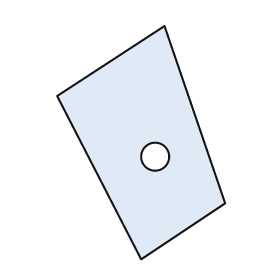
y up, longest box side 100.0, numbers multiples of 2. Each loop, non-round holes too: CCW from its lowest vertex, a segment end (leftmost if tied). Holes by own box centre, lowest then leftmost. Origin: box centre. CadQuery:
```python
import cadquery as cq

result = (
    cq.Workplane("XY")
    .moveTo(0.0, -50.0)
    .lineTo(36.0, -26.0)
    .lineTo(10.0, 50.0)
    .lineTo(-36.0, 20.0)
    .close()
    .moveTo(6.0, -6.0)
    .circle(6.0)
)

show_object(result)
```